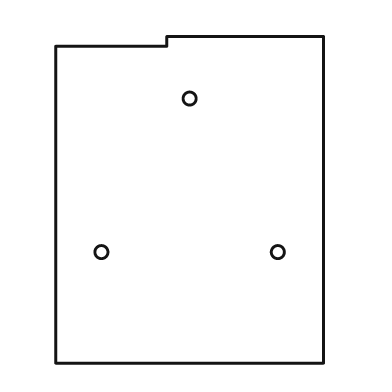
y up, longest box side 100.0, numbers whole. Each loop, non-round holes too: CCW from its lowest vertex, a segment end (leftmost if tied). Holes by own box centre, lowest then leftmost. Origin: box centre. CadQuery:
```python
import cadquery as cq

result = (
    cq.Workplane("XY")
    .moveTo(-41.0, -50.0)
    .lineTo(41.0, -50.0)
    .lineTo(41.0, 50.0)
    .lineTo(-7.0, 50.0)
    .lineTo(-7.0, 47.0)
    .lineTo(-41.0, 47.0)
    .close()
    .moveTo(-27.0, -16.0)
    .circle(2.0)
    .moveTo(27.0, -16.0)
    .circle(2.0)
    .moveTo(0.0, 31.0)
    .circle(2.0)
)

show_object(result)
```